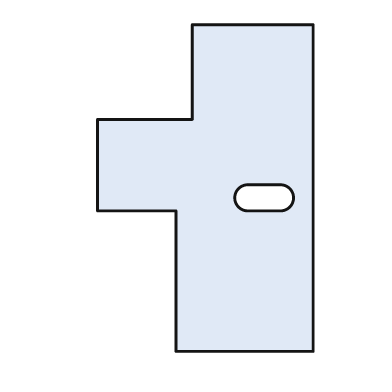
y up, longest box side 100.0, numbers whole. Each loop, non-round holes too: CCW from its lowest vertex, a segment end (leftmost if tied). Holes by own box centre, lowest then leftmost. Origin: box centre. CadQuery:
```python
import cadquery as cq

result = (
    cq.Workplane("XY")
    .moveTo(-9.0, -50.0)
    .lineTo(33.0, -50.0)
    .lineTo(33.0, 50.0)
    .lineTo(-4.0, 50.0)
    .lineTo(-4.0, 21.0)
    .lineTo(-33.0, 21.0)
    .lineTo(-33.0, -7.0)
    .lineTo(-9.0, -7.0)
    .close()
    .moveTo(13.0, -7.0)
    .lineTo(23.0, -7.0)
    .threePointArc((27.0, -3.0), (23.0, 1.0))
    .lineTo(13.0, 1.0)
    .threePointArc((9.0, -3.0), (13.0, -7.0))
    .close()
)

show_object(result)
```